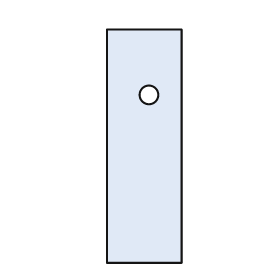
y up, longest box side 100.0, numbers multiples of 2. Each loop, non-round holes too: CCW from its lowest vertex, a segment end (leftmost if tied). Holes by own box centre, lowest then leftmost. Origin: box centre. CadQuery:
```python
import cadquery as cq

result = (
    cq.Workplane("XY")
    .moveTo(-16.0, -50.0)
    .lineTo(16.0, -50.0)
    .lineTo(16.0, 50.0)
    .lineTo(-16.0, 50.0)
    .close()
    .moveTo(2.0, 22.0)
    .circle(4.0)
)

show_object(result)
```